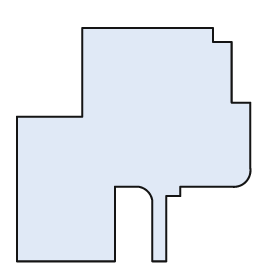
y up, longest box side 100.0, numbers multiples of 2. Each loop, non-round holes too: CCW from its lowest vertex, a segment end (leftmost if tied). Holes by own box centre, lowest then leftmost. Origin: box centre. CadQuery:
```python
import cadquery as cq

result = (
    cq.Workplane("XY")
    .moveTo(-50.0, -50.0)
    .lineTo(-8.0, -50.0)
    .lineTo(-8.0, -18.0)
    .lineTo(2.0, -18.0)
    .threePointArc((6.0, -20.0), (8.0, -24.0))
    .lineTo(8.0, -50.0)
    .lineTo(14.0, -50.0)
    .lineTo(14.0, -22.0)
    .lineTo(20.0, -22.0)
    .lineTo(20.0, -18.0)
    .lineTo(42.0, -18.0)
    .threePointArc((48.0, -16.0), (50.0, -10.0))
    .lineTo(50.0, 18.0)
    .lineTo(42.0, 18.0)
    .lineTo(42.0, 44.0)
    .lineTo(34.0, 44.0)
    .lineTo(34.0, 50.0)
    .lineTo(-22.0, 50.0)
    .lineTo(-22.0, 12.0)
    .lineTo(-50.0, 12.0)
    .close()
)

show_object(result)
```